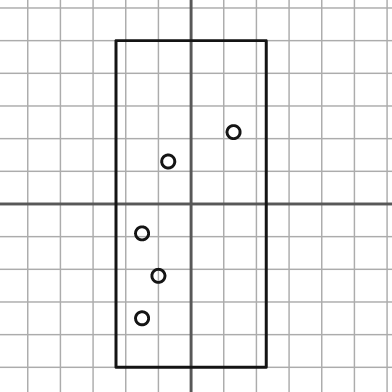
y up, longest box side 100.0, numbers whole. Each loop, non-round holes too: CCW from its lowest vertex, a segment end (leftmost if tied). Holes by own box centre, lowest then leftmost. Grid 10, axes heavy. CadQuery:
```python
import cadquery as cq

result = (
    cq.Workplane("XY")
    .moveTo(-23.0, -50.0)
    .lineTo(23.0, -50.0)
    .lineTo(23.0, 50.0)
    .lineTo(-23.0, 50.0)
    .close()
    .moveTo(-15.0, -35.0)
    .circle(2.0)
    .moveTo(-10.0, -22.0)
    .circle(2.0)
    .moveTo(-15.0, -9.0)
    .circle(2.0)
    .moveTo(-7.0, 13.0)
    .circle(2.0)
    .moveTo(13.0, 22.0)
    .circle(2.0)
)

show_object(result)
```